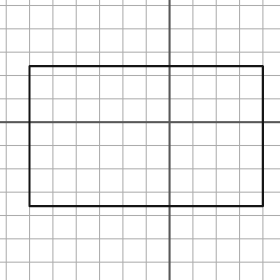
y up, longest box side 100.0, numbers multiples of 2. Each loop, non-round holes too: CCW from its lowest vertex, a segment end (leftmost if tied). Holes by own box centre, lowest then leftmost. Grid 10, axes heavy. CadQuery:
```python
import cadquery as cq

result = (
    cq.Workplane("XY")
    .moveTo(-60.0, -36.0)
    .lineTo(40.0, -36.0)
    .lineTo(40.0, 24.0)
    .lineTo(-60.0, 24.0)
    .close()
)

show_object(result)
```